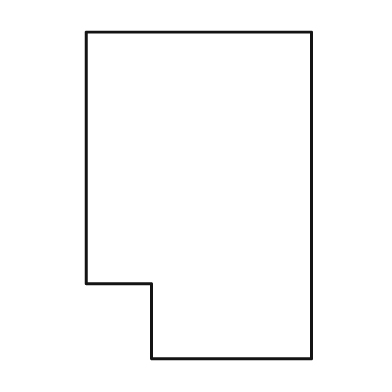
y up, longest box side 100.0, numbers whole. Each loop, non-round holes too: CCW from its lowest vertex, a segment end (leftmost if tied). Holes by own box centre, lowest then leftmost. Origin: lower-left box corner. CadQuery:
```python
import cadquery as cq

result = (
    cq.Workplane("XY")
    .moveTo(20.0, 0.0)
    .lineTo(69.0, 0.0)
    .lineTo(69.0, 100.0)
    .lineTo(0.0, 100.0)
    .lineTo(0.0, 23.0)
    .lineTo(20.0, 23.0)
    .close()
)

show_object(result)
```